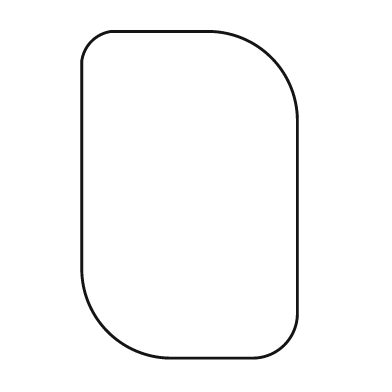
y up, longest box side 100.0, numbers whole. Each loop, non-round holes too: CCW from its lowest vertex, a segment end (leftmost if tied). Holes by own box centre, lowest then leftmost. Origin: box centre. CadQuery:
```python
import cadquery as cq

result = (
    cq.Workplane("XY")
    .moveTo(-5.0, -50.0)
    .lineTo(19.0, -50.0)
    .threePointArc((29.0, -46.0), (33.0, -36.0))
    .lineTo(33.0, 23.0)
    .threePointArc((25.0, 42.0), (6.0, 50.0))
    .lineTo(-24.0, 50.0)
    .threePointArc((-30.0, 47.0), (-33.0, 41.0))
    .lineTo(-33.0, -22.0)
    .threePointArc((-25.0, -42.0), (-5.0, -50.0))
    .close()
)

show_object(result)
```